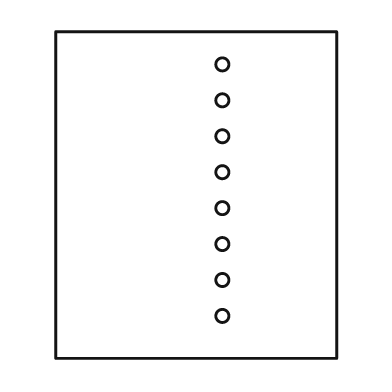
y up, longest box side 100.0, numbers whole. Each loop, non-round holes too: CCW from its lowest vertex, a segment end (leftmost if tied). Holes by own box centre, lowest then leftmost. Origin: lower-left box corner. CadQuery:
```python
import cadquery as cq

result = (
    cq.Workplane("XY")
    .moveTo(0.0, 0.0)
    .lineTo(86.0, 0.0)
    .lineTo(86.0, 100.0)
    .lineTo(0.0, 100.0)
    .close()
    .moveTo(51.0, 13.0)
    .circle(2.0)
    .moveTo(51.0, 24.0)
    .circle(2.0)
    .moveTo(51.0, 35.0)
    .circle(2.0)
    .moveTo(51.0, 46.0)
    .circle(2.0)
    .moveTo(51.0, 57.0)
    .circle(2.0)
    .moveTo(51.0, 68.0)
    .circle(2.0)
    .moveTo(51.0, 79.0)
    .circle(2.0)
    .moveTo(51.0, 90.0)
    .circle(2.0)
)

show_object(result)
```